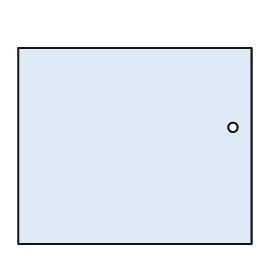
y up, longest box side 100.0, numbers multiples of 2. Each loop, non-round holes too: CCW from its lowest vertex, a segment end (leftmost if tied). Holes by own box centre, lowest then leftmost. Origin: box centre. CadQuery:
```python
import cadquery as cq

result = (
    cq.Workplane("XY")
    .moveTo(-50.0, -42.0)
    .lineTo(50.0, -42.0)
    .lineTo(50.0, 42.0)
    .lineTo(-50.0, 42.0)
    .close()
    .moveTo(42.0, 8.0)
    .circle(2.0)
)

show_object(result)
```